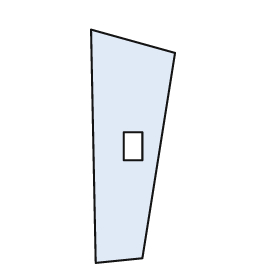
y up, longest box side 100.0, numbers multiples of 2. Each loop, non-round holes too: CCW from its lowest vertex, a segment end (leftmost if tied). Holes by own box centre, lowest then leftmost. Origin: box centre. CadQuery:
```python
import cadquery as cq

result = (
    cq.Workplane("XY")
    .moveTo(-16.0, -50.0)
    .lineTo(4.0, -48.0)
    .lineTo(18.0, 40.0)
    .lineTo(-18.0, 50.0)
    .close()
    .moveTo(-4.0, -6.0)
    .lineTo(4.0, -6.0)
    .lineTo(4.0, 6.0)
    .lineTo(-4.0, 6.0)
    .close()
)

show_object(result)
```